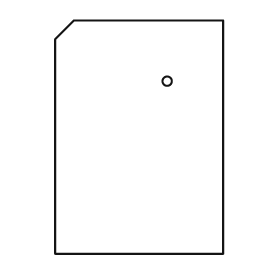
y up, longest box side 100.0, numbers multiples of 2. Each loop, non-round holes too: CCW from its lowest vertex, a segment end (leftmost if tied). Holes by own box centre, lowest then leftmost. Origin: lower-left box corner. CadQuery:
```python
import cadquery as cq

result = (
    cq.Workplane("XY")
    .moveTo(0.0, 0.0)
    .lineTo(72.0, 0.0)
    .lineTo(72.0, 100.0)
    .lineTo(8.0, 100.0)
    .lineTo(0.0, 92.0)
    .close()
    .moveTo(48.0, 74.0)
    .circle(2.0)
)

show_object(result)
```